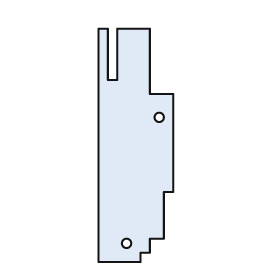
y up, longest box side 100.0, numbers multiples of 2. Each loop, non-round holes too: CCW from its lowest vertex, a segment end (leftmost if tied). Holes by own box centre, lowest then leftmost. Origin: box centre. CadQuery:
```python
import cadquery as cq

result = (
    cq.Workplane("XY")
    .moveTo(-16.0, -50.0)
    .lineTo(2.0, -50.0)
    .lineTo(2.0, -46.0)
    .lineTo(6.0, -46.0)
    .lineTo(6.0, -40.0)
    .lineTo(12.0, -40.0)
    .lineTo(12.0, -20.0)
    .lineTo(16.0, -20.0)
    .lineTo(16.0, 22.0)
    .lineTo(6.0, 22.0)
    .lineTo(6.0, 50.0)
    .lineTo(-8.0, 50.0)
    .lineTo(-8.0, 28.0)
    .lineTo(-12.0, 28.0)
    .lineTo(-12.0, 50.0)
    .lineTo(-16.0, 50.0)
    .close()
    .moveTo(-4.0, -42.0)
    .circle(2.0)
    .moveTo(10.0, 12.0)
    .circle(2.0)
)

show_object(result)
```